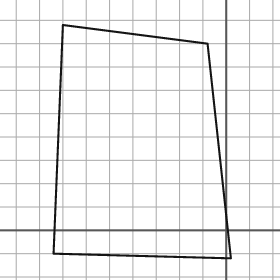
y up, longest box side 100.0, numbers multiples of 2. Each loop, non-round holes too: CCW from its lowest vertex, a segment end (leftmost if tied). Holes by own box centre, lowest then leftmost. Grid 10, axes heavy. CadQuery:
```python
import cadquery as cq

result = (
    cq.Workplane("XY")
    .moveTo(2.0, -12.0)
    .lineTo(-8.0, 80.0)
    .lineTo(-70.0, 88.0)
    .lineTo(-74.0, -10.0)
    .close()
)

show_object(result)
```